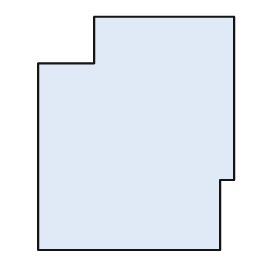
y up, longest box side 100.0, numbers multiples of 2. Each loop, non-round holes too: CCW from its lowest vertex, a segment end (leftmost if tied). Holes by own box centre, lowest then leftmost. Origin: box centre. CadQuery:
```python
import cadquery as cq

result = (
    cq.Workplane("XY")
    .moveTo(-42.0, -50.0)
    .lineTo(36.0, -50.0)
    .lineTo(36.0, -20.0)
    .lineTo(42.0, -20.0)
    .lineTo(42.0, 50.0)
    .lineTo(-18.0, 50.0)
    .lineTo(-18.0, 30.0)
    .lineTo(-42.0, 30.0)
    .close()
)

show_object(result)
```